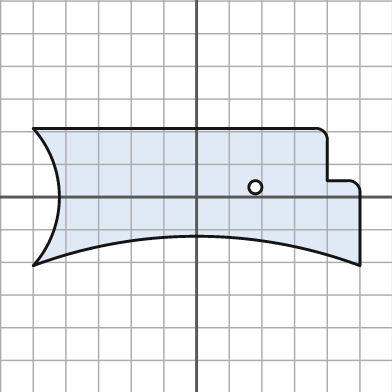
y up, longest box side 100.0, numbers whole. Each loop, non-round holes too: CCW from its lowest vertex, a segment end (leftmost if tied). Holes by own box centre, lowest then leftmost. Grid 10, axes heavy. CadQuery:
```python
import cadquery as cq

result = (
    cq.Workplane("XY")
    .moveTo(-50.0, -21.0)
    .threePointArc((0.0, -12.0), (50.0, -21.0))
    .lineTo(50.0, 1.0)
    .threePointArc((49.0, 4.0), (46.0, 5.0))
    .lineTo(40.0, 5.0)
    .lineTo(40.0, 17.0)
    .threePointArc((39.0, 20.0), (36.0, 21.0))
    .lineTo(-50.0, 21.0)
    .threePointArc((-42.0, 0.0), (-50.0, -21.0))
    .close()
    .moveTo(18.0, 3.0)
    .circle(2.0)
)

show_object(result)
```